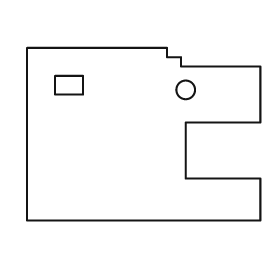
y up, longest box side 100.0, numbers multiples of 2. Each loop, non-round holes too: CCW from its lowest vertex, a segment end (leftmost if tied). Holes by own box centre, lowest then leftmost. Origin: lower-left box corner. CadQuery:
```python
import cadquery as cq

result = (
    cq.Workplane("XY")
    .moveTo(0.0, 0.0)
    .lineTo(100.0, 0.0)
    .lineTo(100.0, 18.0)
    .lineTo(68.0, 18.0)
    .lineTo(68.0, 42.0)
    .lineTo(100.0, 42.0)
    .lineTo(100.0, 66.0)
    .lineTo(66.0, 66.0)
    .lineTo(66.0, 70.0)
    .lineTo(60.0, 70.0)
    .lineTo(60.0, 74.0)
    .lineTo(0.0, 74.0)
    .close()
    .moveTo(68.0, 56.0)
    .circle(4.0)
    .moveTo(12.0, 54.0)
    .lineTo(24.0, 54.0)
    .lineTo(24.0, 62.0)
    .lineTo(12.0, 62.0)
    .close()
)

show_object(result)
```